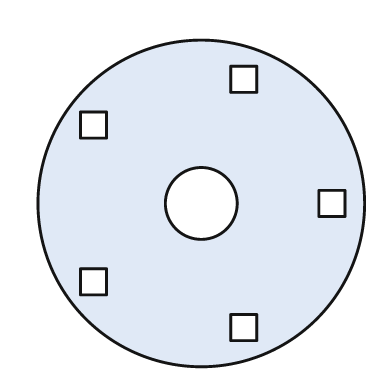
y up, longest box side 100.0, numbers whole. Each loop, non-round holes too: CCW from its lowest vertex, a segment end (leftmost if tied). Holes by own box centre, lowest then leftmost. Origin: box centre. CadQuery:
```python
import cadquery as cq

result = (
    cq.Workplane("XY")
    .moveTo(0.0, 0.0)
    .circle(50.0)
    .moveTo(9.0, -42.0)
    .lineTo(17.0, -42.0)
    .lineTo(17.0, -34.0)
    .lineTo(9.0, -34.0)
    .close()
    .moveTo(-37.0, -28.0)
    .lineTo(-29.0, -28.0)
    .lineTo(-29.0, -20.0)
    .lineTo(-37.0, -20.0)
    .close()
    .moveTo(0.0, 0.0)
    .circle(11.0)
    .moveTo(36.0, -4.0)
    .lineTo(44.0, -4.0)
    .lineTo(44.0, 4.0)
    .lineTo(36.0, 4.0)
    .close()
    .moveTo(-37.0, 20.0)
    .lineTo(-29.0, 20.0)
    .lineTo(-29.0, 28.0)
    .lineTo(-37.0, 28.0)
    .close()
    .moveTo(9.0, 34.0)
    .lineTo(17.0, 34.0)
    .lineTo(17.0, 42.0)
    .lineTo(9.0, 42.0)
    .close()
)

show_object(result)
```